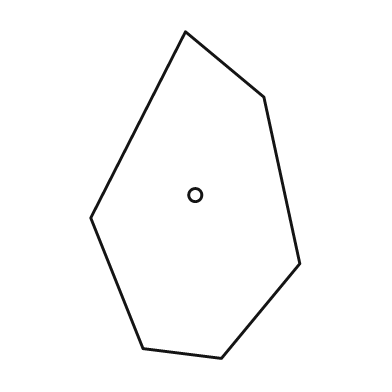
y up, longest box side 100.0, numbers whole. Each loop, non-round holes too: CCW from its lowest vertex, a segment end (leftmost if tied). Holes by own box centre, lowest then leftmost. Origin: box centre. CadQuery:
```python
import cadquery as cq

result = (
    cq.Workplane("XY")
    .moveTo(8.0, -50.0)
    .lineTo(32.0, -21.0)
    .lineTo(21.0, 30.0)
    .lineTo(-3.0, 50.0)
    .lineTo(-32.0, -7.0)
    .lineTo(-16.0, -47.0)
    .close()
    .moveTo(0.0, 0.0)
    .circle(2.0)
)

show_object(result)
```